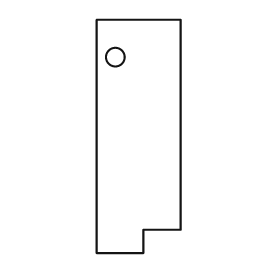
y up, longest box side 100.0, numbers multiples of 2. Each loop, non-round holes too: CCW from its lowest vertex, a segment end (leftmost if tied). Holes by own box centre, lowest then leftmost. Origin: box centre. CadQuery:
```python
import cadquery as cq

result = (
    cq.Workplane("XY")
    .moveTo(-18.0, -50.0)
    .lineTo(2.0, -50.0)
    .lineTo(2.0, -40.0)
    .lineTo(18.0, -40.0)
    .lineTo(18.0, 50.0)
    .lineTo(-18.0, 50.0)
    .close()
    .moveTo(-10.0, 34.0)
    .circle(4.0)
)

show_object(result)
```